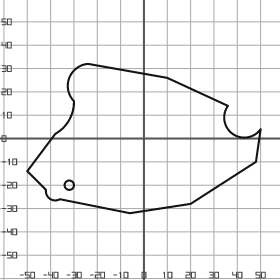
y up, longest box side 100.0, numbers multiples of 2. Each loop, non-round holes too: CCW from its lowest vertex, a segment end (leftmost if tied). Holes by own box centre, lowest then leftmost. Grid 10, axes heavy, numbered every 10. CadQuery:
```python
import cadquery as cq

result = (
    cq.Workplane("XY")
    .moveTo(-6.0, -32.0)
    .lineTo(20.0, -28.0)
    .lineTo(48.0, -10.0)
    .lineTo(50.0, 4.0)
    .threePointArc((38.0, 2.0), (36.0, 14.0))
    .lineTo(10.0, 26.0)
    .lineTo(-24.0, 32.0)
    .threePointArc((-32.0, 26.0), (-30.0, 16.0))
    .threePointArc((-32.0, 8.0), (-38.0, 2.0))
    .lineTo(-50.0, -14.0)
    .lineTo(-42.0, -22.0)
    .threePointArc((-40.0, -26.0), (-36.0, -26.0))
    .close()
    .moveTo(-32.0, -20.0)
    .circle(2.0)
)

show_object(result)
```